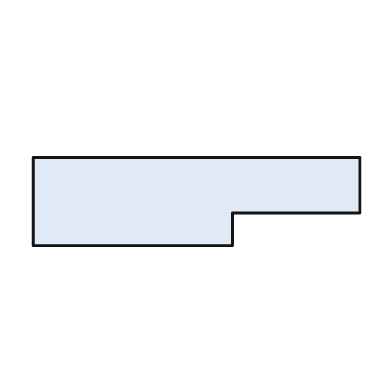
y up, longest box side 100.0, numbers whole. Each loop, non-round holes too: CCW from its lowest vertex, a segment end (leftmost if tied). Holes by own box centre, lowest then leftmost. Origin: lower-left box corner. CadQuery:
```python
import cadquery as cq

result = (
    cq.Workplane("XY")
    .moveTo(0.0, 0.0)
    .lineTo(61.0, 0.0)
    .lineTo(61.0, 10.0)
    .lineTo(100.0, 10.0)
    .lineTo(100.0, 27.0)
    .lineTo(0.0, 27.0)
    .close()
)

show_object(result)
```